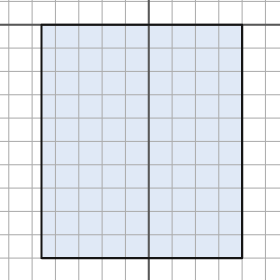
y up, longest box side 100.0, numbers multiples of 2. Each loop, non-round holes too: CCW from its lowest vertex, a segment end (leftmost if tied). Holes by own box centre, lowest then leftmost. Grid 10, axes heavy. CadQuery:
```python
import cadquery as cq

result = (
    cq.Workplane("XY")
    .moveTo(-46.0, -100.0)
    .lineTo(40.0, -100.0)
    .lineTo(40.0, 0.0)
    .lineTo(-46.0, 0.0)
    .close()
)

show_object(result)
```